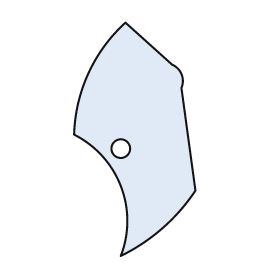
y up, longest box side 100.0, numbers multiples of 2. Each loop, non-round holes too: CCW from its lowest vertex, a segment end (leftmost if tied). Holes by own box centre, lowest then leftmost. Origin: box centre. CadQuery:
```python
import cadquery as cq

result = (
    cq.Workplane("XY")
    .moveTo(-6.0, -50.0)
    .threePointArc((12.0, -38.0), (26.0, -22.0))
    .lineTo(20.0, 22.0)
    .threePointArc((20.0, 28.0), (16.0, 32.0))
    .lineTo(-4.0, 50.0)
    .threePointArc((-20.0, 28.0), (-26.0, 2.0))
    .threePointArc((-6.0, -20.0), (-6.0, -50.0))
    .close()
    .moveTo(-6.0, -4.0)
    .circle(4.0)
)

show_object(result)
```